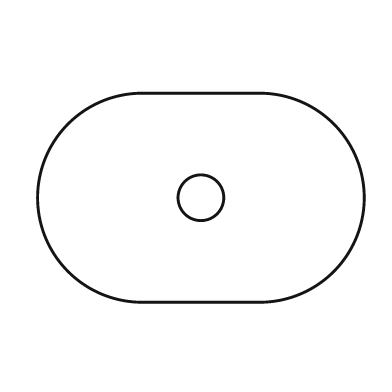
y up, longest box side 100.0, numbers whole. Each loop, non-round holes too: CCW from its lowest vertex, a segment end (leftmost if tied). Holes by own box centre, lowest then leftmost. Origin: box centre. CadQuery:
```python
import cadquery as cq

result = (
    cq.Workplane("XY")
    .moveTo(-18.0, -32.0)
    .lineTo(18.0, -32.0)
    .threePointArc((50.0, 0.0), (18.0, 32.0))
    .lineTo(-18.0, 32.0)
    .threePointArc((-50.0, 0.0), (-18.0, -32.0))
    .close()
    .moveTo(0.0, 0.0)
    .circle(7.0)
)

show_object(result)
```